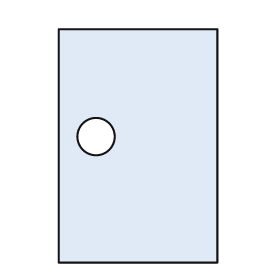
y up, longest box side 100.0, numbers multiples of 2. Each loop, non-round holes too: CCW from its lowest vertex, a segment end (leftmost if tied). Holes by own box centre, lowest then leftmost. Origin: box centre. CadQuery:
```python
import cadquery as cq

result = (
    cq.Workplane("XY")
    .moveTo(-34.0, -50.0)
    .lineTo(34.0, -50.0)
    .lineTo(34.0, 50.0)
    .lineTo(-34.0, 50.0)
    .close()
    .moveTo(-18.0, 4.0)
    .circle(8.0)
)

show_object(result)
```